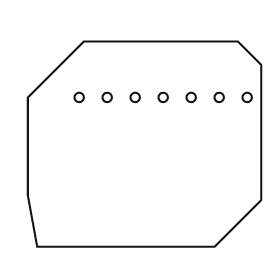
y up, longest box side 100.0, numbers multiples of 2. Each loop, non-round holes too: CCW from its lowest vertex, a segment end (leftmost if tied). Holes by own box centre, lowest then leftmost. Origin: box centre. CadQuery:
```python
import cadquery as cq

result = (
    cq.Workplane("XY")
    .moveTo(-46.0, -44.0)
    .lineTo(30.0, -44.0)
    .lineTo(50.0, -24.0)
    .lineTo(50.0, 34.0)
    .lineTo(40.0, 44.0)
    .lineTo(-26.0, 44.0)
    .lineTo(-50.0, 20.0)
    .lineTo(-50.0, -22.0)
    .close()
    .moveTo(-28.0, 20.0)
    .circle(2.0)
    .moveTo(-16.0, 20.0)
    .circle(2.0)
    .moveTo(-4.0, 20.0)
    .circle(2.0)
    .moveTo(8.0, 20.0)
    .circle(2.0)
    .moveTo(20.0, 20.0)
    .circle(2.0)
    .moveTo(32.0, 20.0)
    .circle(2.0)
    .moveTo(44.0, 20.0)
    .circle(2.0)
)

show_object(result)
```